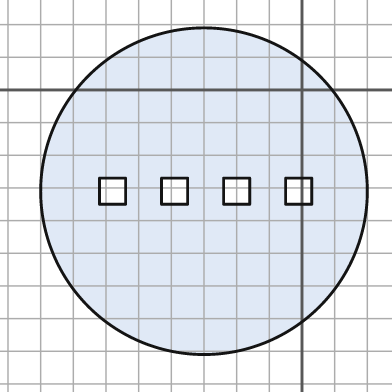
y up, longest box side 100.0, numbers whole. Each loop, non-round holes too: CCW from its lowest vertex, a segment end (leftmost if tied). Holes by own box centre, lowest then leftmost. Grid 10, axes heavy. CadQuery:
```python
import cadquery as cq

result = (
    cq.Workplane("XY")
    .moveTo(-30.0, -31.0)
    .circle(50.0)
    .moveTo(-62.0, -35.0)
    .lineTo(-54.0, -35.0)
    .lineTo(-54.0, -27.0)
    .lineTo(-62.0, -27.0)
    .close()
    .moveTo(-43.0, -35.0)
    .lineTo(-35.0, -35.0)
    .lineTo(-35.0, -27.0)
    .lineTo(-43.0, -27.0)
    .close()
    .moveTo(-24.0, -35.0)
    .lineTo(-16.0, -35.0)
    .lineTo(-16.0, -27.0)
    .lineTo(-24.0, -27.0)
    .close()
    .moveTo(-5.0, -35.0)
    .lineTo(3.0, -35.0)
    .lineTo(3.0, -27.0)
    .lineTo(-5.0, -27.0)
    .close()
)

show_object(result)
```